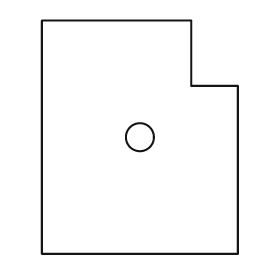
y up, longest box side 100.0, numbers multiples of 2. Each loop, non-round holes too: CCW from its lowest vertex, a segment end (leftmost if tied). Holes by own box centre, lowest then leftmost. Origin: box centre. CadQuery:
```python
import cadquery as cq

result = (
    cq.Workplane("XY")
    .moveTo(-42.0, -50.0)
    .lineTo(42.0, -50.0)
    .lineTo(42.0, 22.0)
    .lineTo(22.0, 22.0)
    .lineTo(22.0, 50.0)
    .lineTo(-42.0, 50.0)
    .close()
    .moveTo(0.0, 0.0)
    .circle(6.0)
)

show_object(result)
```